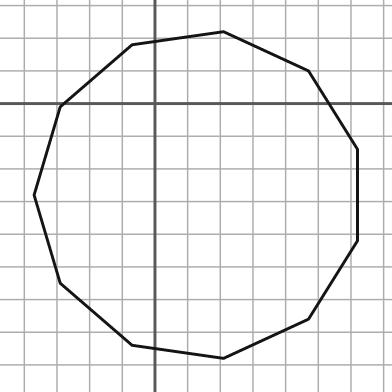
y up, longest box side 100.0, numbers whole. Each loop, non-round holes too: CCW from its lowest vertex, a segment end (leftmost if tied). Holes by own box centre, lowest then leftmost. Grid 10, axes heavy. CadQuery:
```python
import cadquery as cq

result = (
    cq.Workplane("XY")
    .moveTo(21.0, -78.0)
    .lineTo(47.0, -66.0)
    .lineTo(62.0, -42.0)
    .lineTo(62.0, -14.0)
    .lineTo(47.0, 10.0)
    .lineTo(21.0, 22.0)
    .lineTo(-7.0, 18.0)
    .lineTo(-29.0, -1.0)
    .lineTo(-37.0, -28.0)
    .lineTo(-29.0, -55.0)
    .lineTo(-7.0, -74.0)
    .close()
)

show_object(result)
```